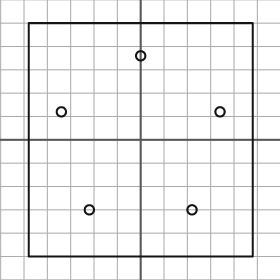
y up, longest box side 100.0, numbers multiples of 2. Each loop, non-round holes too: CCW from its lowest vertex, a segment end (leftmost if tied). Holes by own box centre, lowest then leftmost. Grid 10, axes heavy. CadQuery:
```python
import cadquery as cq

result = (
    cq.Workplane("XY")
    .moveTo(-48.0, -50.0)
    .lineTo(48.0, -50.0)
    .lineTo(48.0, 50.0)
    .lineTo(-48.0, 50.0)
    .close()
    .moveTo(-22.0, -30.0)
    .circle(2.0)
    .moveTo(22.0, -30.0)
    .circle(2.0)
    .moveTo(-34.0, 12.0)
    .circle(2.0)
    .moveTo(34.0, 12.0)
    .circle(2.0)
    .moveTo(0.0, 36.0)
    .circle(2.0)
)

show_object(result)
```